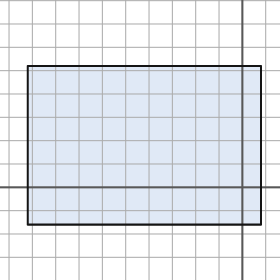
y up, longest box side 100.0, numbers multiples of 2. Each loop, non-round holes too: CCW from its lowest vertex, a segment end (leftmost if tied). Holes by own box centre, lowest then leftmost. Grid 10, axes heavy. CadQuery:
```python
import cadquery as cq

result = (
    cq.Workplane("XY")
    .moveTo(-92.0, -16.0)
    .lineTo(8.0, -16.0)
    .lineTo(8.0, 52.0)
    .lineTo(-92.0, 52.0)
    .close()
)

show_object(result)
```